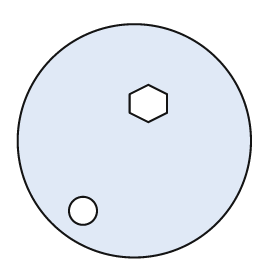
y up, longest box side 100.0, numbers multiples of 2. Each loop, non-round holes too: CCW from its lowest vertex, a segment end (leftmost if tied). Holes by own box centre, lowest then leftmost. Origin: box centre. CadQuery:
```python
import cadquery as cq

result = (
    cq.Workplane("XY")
    .moveTo(0.0, 0.0)
    .circle(50.0)
    .moveTo(-22.0, -30.0)
    .circle(6.0)
    .moveTo(6.0, 8.0)
    .lineTo(14.0, 12.0)
    .lineTo(14.0, 20.0)
    .lineTo(6.0, 24.0)
    .lineTo(-2.0, 20.0)
    .lineTo(-2.0, 12.0)
    .close()
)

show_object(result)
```